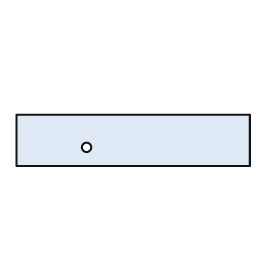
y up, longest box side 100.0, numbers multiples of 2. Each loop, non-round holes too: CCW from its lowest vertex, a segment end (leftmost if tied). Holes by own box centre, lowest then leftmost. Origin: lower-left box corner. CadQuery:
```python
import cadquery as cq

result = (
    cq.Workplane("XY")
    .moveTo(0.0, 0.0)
    .lineTo(100.0, 0.0)
    .lineTo(100.0, 22.0)
    .lineTo(0.0, 22.0)
    .close()
    .moveTo(30.0, 8.0)
    .circle(2.0)
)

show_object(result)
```